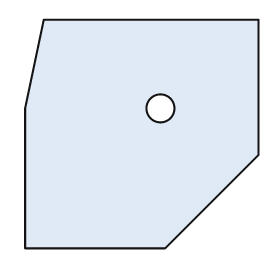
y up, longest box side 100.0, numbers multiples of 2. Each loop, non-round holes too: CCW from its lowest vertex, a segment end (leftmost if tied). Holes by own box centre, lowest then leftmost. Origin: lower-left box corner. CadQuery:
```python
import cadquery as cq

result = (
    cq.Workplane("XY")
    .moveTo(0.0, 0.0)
    .lineTo(60.0, 0.0)
    .lineTo(100.0, 40.0)
    .lineTo(100.0, 98.0)
    .lineTo(8.0, 98.0)
    .lineTo(0.0, 60.0)
    .close()
    .moveTo(58.0, 60.0)
    .circle(6.0)
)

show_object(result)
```